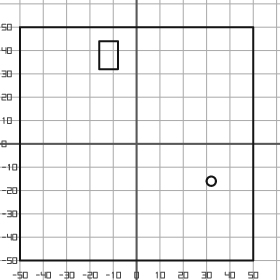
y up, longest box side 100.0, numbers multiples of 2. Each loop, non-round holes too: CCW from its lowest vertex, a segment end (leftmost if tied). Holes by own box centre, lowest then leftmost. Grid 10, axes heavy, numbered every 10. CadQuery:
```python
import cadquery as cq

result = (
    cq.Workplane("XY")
    .moveTo(-50.0, -50.0)
    .lineTo(50.0, -50.0)
    .lineTo(50.0, 50.0)
    .lineTo(-50.0, 50.0)
    .close()
    .moveTo(32.0, -16.0)
    .circle(2.0)
    .moveTo(-16.0, 32.0)
    .lineTo(-8.0, 32.0)
    .lineTo(-8.0, 44.0)
    .lineTo(-16.0, 44.0)
    .close()
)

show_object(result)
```